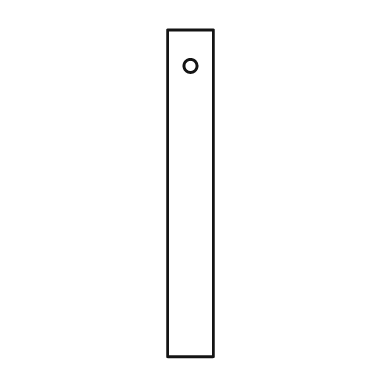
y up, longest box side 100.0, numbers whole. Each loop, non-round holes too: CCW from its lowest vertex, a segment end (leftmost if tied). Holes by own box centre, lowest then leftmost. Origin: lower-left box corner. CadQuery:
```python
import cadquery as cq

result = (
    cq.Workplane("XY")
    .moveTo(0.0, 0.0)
    .lineTo(14.0, 0.0)
    .lineTo(14.0, 100.0)
    .lineTo(0.0, 100.0)
    .close()
    .moveTo(7.0, 89.0)
    .circle(2.0)
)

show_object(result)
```